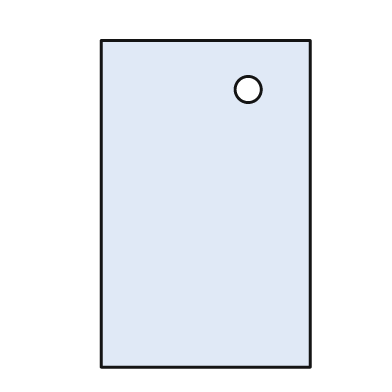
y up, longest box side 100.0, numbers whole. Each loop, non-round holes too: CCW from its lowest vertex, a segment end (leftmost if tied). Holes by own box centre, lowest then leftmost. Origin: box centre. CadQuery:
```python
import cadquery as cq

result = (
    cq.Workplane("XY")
    .moveTo(-32.0, -50.0)
    .lineTo(32.0, -50.0)
    .lineTo(32.0, 50.0)
    .lineTo(-32.0, 50.0)
    .close()
    .moveTo(13.0, 35.0)
    .circle(4.0)
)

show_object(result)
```